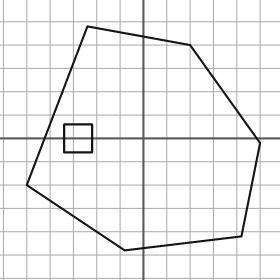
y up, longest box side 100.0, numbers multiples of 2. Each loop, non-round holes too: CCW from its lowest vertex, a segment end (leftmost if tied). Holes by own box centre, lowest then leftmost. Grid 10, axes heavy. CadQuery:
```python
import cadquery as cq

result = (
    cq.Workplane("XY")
    .moveTo(-8.0, -48.0)
    .lineTo(42.0, -42.0)
    .lineTo(50.0, -2.0)
    .lineTo(20.0, 40.0)
    .lineTo(-24.0, 48.0)
    .lineTo(-50.0, -20.0)
    .close()
    .moveTo(-34.0, -6.0)
    .lineTo(-22.0, -6.0)
    .lineTo(-22.0, 6.0)
    .lineTo(-34.0, 6.0)
    .close()
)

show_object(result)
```